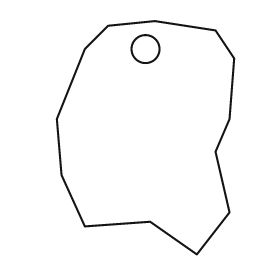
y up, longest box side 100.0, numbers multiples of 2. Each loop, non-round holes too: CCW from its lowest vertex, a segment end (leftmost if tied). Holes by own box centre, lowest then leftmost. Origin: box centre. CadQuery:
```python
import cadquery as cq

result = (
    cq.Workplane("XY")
    .moveTo(22.0, -50.0)
    .lineTo(36.0, -32.0)
    .lineTo(30.0, -6.0)
    .lineTo(36.0, 8.0)
    .lineTo(38.0, 34.0)
    .lineTo(30.0, 46.0)
    .lineTo(4.0, 50.0)
    .lineTo(-16.0, 48.0)
    .lineTo(-26.0, 38.0)
    .lineTo(-38.0, 8.0)
    .lineTo(-36.0, -16.0)
    .lineTo(-26.0, -38.0)
    .lineTo(2.0, -36.0)
    .close()
    .moveTo(0.0, 38.0)
    .circle(6.0)
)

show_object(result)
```